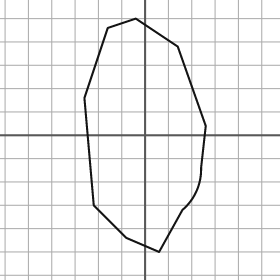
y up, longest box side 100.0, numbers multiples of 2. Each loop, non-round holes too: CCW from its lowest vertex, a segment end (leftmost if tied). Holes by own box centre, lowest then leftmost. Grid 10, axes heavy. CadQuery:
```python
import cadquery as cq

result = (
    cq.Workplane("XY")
    .moveTo(6.0, -50.0)
    .lineTo(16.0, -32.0)
    .threePointArc((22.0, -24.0), (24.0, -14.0))
    .lineTo(26.0, 4.0)
    .lineTo(14.0, 38.0)
    .lineTo(-4.0, 50.0)
    .lineTo(-16.0, 46.0)
    .lineTo(-26.0, 16.0)
    .lineTo(-22.0, -30.0)
    .lineTo(-8.0, -44.0)
    .close()
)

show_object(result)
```